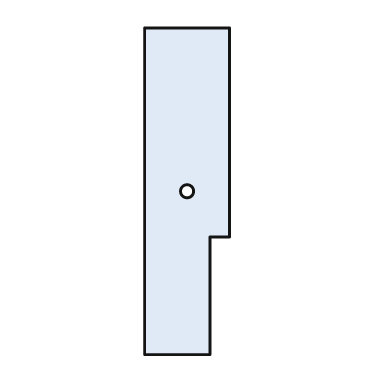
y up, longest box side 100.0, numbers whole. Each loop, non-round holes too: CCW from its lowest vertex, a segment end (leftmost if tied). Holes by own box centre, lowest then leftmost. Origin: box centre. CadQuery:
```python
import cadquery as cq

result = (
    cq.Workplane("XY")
    .moveTo(-13.0, -50.0)
    .lineTo(7.0, -50.0)
    .lineTo(7.0, -14.0)
    .lineTo(13.0, -14.0)
    .lineTo(13.0, 50.0)
    .lineTo(-13.0, 50.0)
    .close()
    .moveTo(0.0, 0.0)
    .circle(2.0)
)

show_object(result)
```